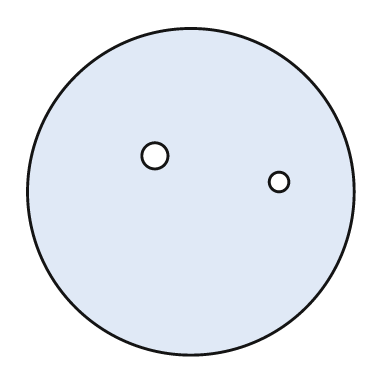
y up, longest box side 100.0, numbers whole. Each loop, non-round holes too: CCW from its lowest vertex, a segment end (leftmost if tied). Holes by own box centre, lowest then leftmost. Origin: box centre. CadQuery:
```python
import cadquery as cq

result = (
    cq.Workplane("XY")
    .moveTo(0.0, 0.0)
    .circle(50.0)
    .moveTo(27.0, 3.0)
    .circle(3.0)
    .moveTo(-11.0, 11.0)
    .circle(4.0)
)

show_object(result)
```